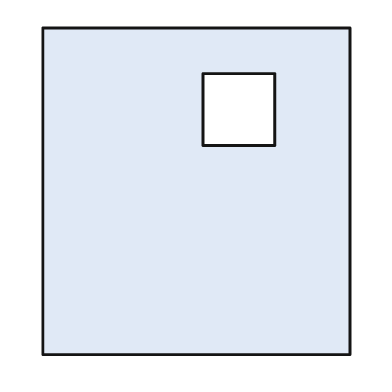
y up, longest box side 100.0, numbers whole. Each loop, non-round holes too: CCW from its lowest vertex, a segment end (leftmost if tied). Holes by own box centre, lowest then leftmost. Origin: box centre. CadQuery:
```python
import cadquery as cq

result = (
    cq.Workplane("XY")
    .moveTo(-47.0, -50.0)
    .lineTo(47.0, -50.0)
    .lineTo(47.0, 50.0)
    .lineTo(-47.0, 50.0)
    .close()
    .moveTo(2.0, 14.0)
    .lineTo(24.0, 14.0)
    .lineTo(24.0, 36.0)
    .lineTo(2.0, 36.0)
    .close()
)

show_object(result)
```